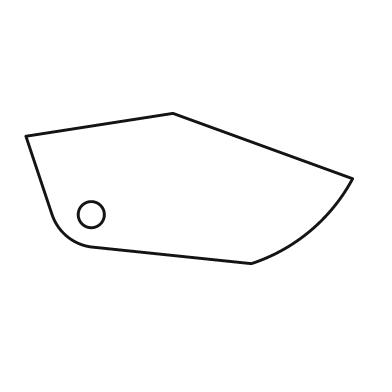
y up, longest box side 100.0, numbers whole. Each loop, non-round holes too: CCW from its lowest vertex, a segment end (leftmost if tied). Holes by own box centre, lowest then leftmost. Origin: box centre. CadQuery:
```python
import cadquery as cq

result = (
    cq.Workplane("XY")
    .moveTo(19.0, -23.0)
    .threePointArc((37.0, -13.0), (50.0, 3.0))
    .lineTo(-5.0, 23.0)
    .lineTo(-50.0, 16.0)
    .lineTo(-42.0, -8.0)
    .threePointArc((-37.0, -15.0), (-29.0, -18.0))
    .close()
    .moveTo(-30.0, -8.0)
    .circle(4.0)
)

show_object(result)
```